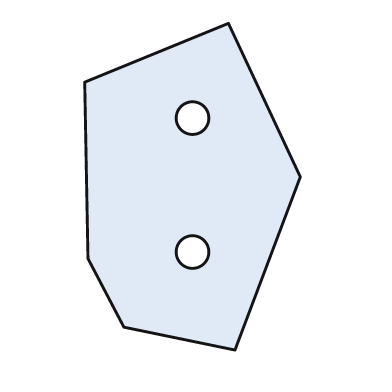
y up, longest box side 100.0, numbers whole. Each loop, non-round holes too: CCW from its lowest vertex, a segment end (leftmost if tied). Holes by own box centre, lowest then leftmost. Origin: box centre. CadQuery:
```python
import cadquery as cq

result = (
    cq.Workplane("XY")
    .moveTo(13.0, -50.0)
    .lineTo(33.0, 3.0)
    .lineTo(11.0, 50.0)
    .lineTo(-33.0, 32.0)
    .lineTo(-32.0, -22.0)
    .lineTo(-21.0, -43.0)
    .close()
    .moveTo(0.0, -20.0)
    .circle(5.0)
    .moveTo(0.0, 21.0)
    .circle(5.0)
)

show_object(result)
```